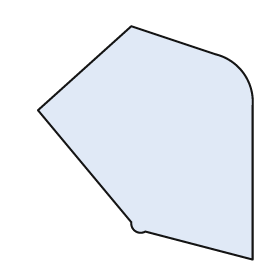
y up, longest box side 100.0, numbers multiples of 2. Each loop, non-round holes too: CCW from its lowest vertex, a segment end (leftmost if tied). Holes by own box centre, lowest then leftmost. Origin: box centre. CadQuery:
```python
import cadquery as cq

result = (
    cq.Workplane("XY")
    .moveTo(46.0, -50.0)
    .lineTo(46.0, 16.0)
    .threePointArc((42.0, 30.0), (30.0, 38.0))
    .lineTo(-6.0, 50.0)
    .lineTo(-46.0, 14.0)
    .lineTo(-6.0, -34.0)
    .threePointArc((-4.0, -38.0), (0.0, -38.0))
    .close()
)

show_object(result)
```